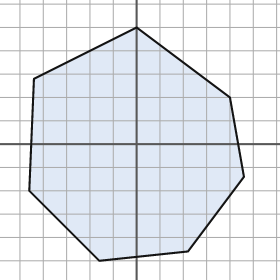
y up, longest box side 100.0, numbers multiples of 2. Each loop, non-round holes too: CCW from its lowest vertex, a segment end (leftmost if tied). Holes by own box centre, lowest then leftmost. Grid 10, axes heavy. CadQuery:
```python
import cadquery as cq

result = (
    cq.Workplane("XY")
    .moveTo(-16.0, -50.0)
    .lineTo(22.0, -46.0)
    .lineTo(46.0, -14.0)
    .lineTo(40.0, 20.0)
    .lineTo(0.0, 50.0)
    .lineTo(-44.0, 28.0)
    .lineTo(-46.0, -20.0)
    .close()
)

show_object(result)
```